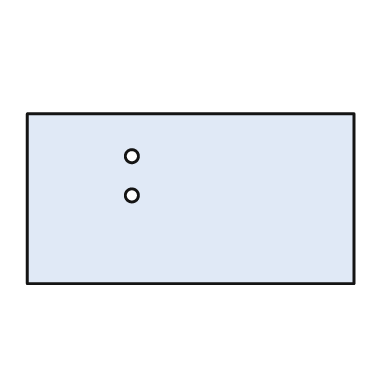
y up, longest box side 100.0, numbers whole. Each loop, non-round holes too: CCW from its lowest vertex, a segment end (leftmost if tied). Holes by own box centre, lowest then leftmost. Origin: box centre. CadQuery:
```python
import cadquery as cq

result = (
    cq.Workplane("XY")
    .moveTo(-50.0, -26.0)
    .lineTo(50.0, -26.0)
    .lineTo(50.0, 26.0)
    .lineTo(-50.0, 26.0)
    .close()
    .moveTo(-18.0, 1.0)
    .circle(2.0)
    .moveTo(-18.0, 13.0)
    .circle(2.0)
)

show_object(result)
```